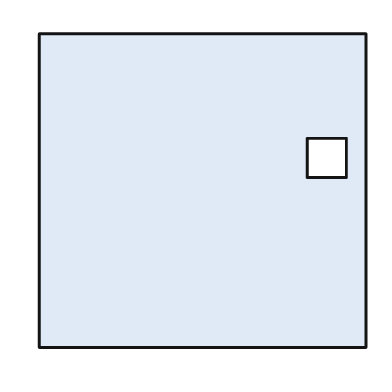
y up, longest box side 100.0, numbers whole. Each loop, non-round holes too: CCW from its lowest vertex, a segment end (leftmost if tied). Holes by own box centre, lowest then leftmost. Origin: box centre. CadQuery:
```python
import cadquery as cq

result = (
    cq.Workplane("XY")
    .moveTo(-50.0, -48.0)
    .lineTo(50.0, -48.0)
    .lineTo(50.0, 48.0)
    .lineTo(-50.0, 48.0)
    .close()
    .moveTo(32.0, 4.0)
    .lineTo(44.0, 4.0)
    .lineTo(44.0, 16.0)
    .lineTo(32.0, 16.0)
    .close()
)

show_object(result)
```